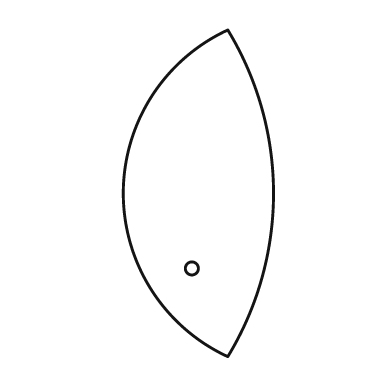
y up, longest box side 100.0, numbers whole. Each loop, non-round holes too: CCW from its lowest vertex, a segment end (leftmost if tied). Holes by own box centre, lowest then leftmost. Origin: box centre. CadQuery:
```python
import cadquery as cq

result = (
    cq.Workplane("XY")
    .moveTo(9.0, -50.0)
    .threePointArc((23.0, 0.0), (9.0, 50.0))
    .threePointArc((-23.0, 0.0), (9.0, -50.0))
    .close()
    .moveTo(-2.0, -23.0)
    .circle(2.0)
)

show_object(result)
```